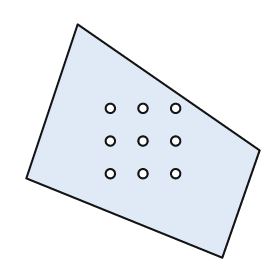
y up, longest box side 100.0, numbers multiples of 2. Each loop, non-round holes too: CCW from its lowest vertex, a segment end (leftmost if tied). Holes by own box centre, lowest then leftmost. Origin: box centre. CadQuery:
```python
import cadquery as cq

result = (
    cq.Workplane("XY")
    .moveTo(34.0, -50.0)
    .lineTo(50.0, -4.0)
    .lineTo(-28.0, 50.0)
    .lineTo(-50.0, -16.0)
    .close()
    .moveTo(-14.0, -14.0)
    .circle(2.0)
    .moveTo(0.0, -14.0)
    .circle(2.0)
    .moveTo(14.0, -14.0)
    .circle(2.0)
    .moveTo(-14.0, 0.0)
    .circle(2.0)
    .moveTo(0.0, 0.0)
    .circle(2.0)
    .moveTo(14.0, 0.0)
    .circle(2.0)
    .moveTo(-14.0, 14.0)
    .circle(2.0)
    .moveTo(0.0, 14.0)
    .circle(2.0)
    .moveTo(14.0, 14.0)
    .circle(2.0)
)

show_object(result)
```